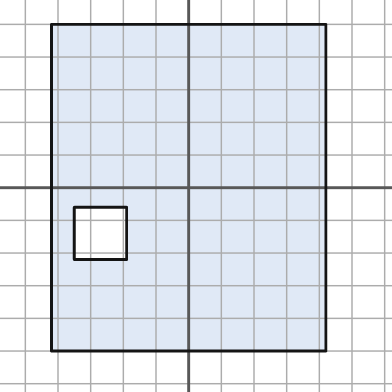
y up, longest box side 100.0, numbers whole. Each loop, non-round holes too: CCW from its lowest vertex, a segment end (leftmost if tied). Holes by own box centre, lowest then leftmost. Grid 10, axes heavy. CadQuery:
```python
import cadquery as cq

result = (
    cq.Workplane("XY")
    .moveTo(-42.0, -50.0)
    .lineTo(42.0, -50.0)
    .lineTo(42.0, 50.0)
    .lineTo(-42.0, 50.0)
    .close()
    .moveTo(-35.0, -22.0)
    .lineTo(-19.0, -22.0)
    .lineTo(-19.0, -6.0)
    .lineTo(-35.0, -6.0)
    .close()
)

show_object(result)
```